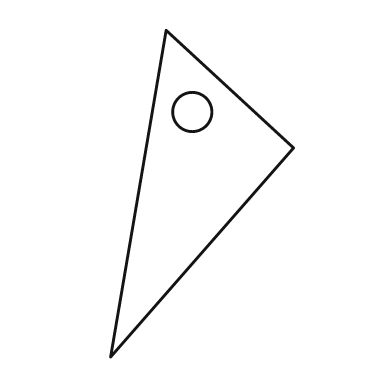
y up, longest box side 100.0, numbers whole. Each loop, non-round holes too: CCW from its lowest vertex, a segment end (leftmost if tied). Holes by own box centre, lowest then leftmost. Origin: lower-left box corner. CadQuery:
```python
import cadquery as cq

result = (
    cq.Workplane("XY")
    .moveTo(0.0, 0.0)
    .lineTo(56.0, 64.0)
    .lineTo(17.0, 100.0)
    .close()
    .moveTo(25.0, 75.0)
    .circle(6.0)
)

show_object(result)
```